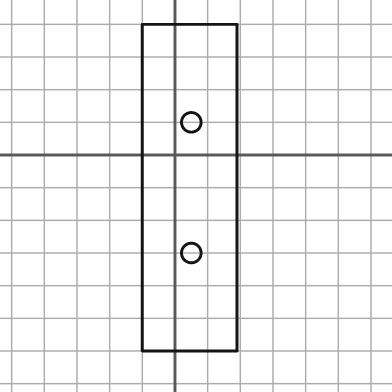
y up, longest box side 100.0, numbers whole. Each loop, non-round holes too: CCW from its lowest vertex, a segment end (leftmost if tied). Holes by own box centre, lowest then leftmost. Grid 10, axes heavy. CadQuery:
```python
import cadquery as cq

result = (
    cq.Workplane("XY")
    .moveTo(-10.0, -60.0)
    .lineTo(19.0, -60.0)
    .lineTo(19.0, 40.0)
    .lineTo(-10.0, 40.0)
    .close()
    .moveTo(5.0, -30.0)
    .circle(3.0)
    .moveTo(5.0, 10.0)
    .circle(3.0)
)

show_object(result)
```